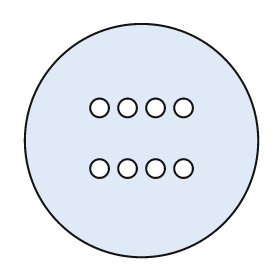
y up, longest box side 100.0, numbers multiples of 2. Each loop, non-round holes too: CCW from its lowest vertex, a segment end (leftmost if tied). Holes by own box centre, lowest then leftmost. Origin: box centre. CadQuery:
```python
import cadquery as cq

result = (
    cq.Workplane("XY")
    .moveTo(0.0, 0.0)
    .circle(50.0)
    .moveTo(-18.0, -12.0)
    .circle(4.0)
    .moveTo(-6.0, -12.0)
    .circle(4.0)
    .moveTo(6.0, -12.0)
    .circle(4.0)
    .moveTo(18.0, -12.0)
    .circle(4.0)
    .moveTo(-18.0, 14.0)
    .circle(4.0)
    .moveTo(-6.0, 14.0)
    .circle(4.0)
    .moveTo(6.0, 14.0)
    .circle(4.0)
    .moveTo(18.0, 14.0)
    .circle(4.0)
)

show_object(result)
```